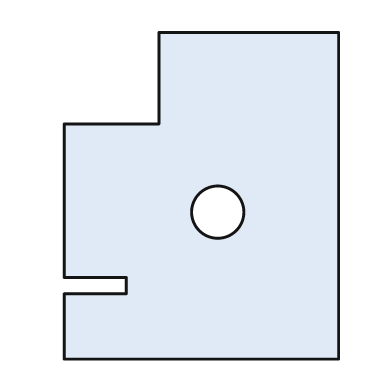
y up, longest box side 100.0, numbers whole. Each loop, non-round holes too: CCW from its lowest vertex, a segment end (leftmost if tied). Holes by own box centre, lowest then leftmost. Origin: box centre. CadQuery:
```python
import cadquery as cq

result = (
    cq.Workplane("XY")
    .moveTo(-42.0, -50.0)
    .lineTo(42.0, -50.0)
    .lineTo(42.0, 50.0)
    .lineTo(-13.0, 50.0)
    .lineTo(-13.0, 22.0)
    .lineTo(-42.0, 22.0)
    .lineTo(-42.0, -25.0)
    .lineTo(-23.0, -25.0)
    .lineTo(-23.0, -30.0)
    .lineTo(-42.0, -30.0)
    .close()
    .moveTo(5.0, -5.0)
    .circle(8.0)
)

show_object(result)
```